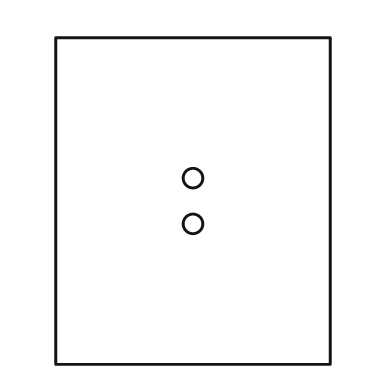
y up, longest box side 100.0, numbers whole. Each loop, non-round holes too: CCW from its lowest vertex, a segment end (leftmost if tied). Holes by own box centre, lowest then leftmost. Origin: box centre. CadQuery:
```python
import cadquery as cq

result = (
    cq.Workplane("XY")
    .moveTo(-42.0, -50.0)
    .lineTo(42.0, -50.0)
    .lineTo(42.0, 50.0)
    .lineTo(-42.0, 50.0)
    .close()
    .moveTo(0.0, -7.0)
    .circle(3.0)
    .moveTo(0.0, 7.0)
    .circle(3.0)
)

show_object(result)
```